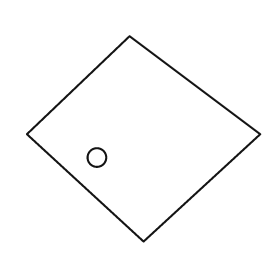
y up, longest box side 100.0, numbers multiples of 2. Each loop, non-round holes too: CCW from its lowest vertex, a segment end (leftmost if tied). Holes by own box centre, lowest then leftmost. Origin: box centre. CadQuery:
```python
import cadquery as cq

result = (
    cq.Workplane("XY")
    .moveTo(0.0, -44.0)
    .lineTo(50.0, 2.0)
    .lineTo(-6.0, 44.0)
    .lineTo(-50.0, 2.0)
    .close()
    .moveTo(-20.0, -8.0)
    .circle(4.0)
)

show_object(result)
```